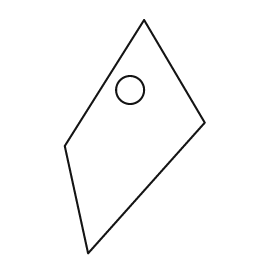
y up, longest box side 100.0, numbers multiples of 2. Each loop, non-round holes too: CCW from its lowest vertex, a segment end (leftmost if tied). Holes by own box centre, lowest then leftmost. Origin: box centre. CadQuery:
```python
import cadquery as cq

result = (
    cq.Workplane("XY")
    .moveTo(-20.0, -50.0)
    .lineTo(30.0, 6.0)
    .lineTo(4.0, 50.0)
    .lineTo(-30.0, -4.0)
    .close()
    .moveTo(-2.0, 20.0)
    .circle(6.0)
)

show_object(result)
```